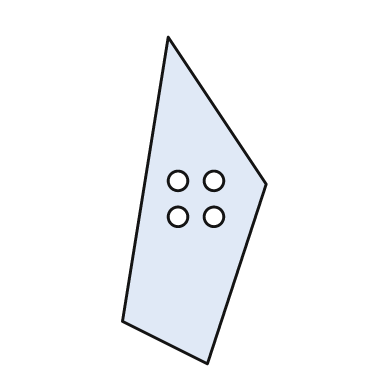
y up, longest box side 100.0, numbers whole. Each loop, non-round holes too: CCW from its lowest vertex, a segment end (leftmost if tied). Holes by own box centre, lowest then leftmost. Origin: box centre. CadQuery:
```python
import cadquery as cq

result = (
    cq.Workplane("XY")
    .moveTo(4.0, -50.0)
    .lineTo(22.0, 5.0)
    .lineTo(-8.0, 50.0)
    .lineTo(-22.0, -37.0)
    .close()
    .moveTo(-5.0, -5.0)
    .circle(3.0)
    .moveTo(6.0, -5.0)
    .circle(3.0)
    .moveTo(-5.0, 6.0)
    .circle(3.0)
    .moveTo(6.0, 6.0)
    .circle(3.0)
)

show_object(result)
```